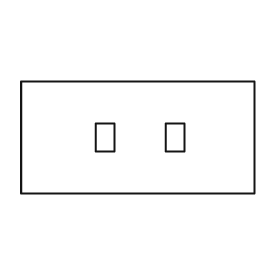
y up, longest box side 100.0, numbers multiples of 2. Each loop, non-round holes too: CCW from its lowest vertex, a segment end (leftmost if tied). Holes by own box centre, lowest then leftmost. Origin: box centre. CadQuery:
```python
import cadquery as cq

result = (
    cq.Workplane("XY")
    .moveTo(-50.0, -24.0)
    .lineTo(50.0, -24.0)
    .lineTo(50.0, 24.0)
    .lineTo(-50.0, 24.0)
    .close()
    .moveTo(-18.0, -6.0)
    .lineTo(-10.0, -6.0)
    .lineTo(-10.0, 6.0)
    .lineTo(-18.0, 6.0)
    .close()
    .moveTo(12.0, -6.0)
    .lineTo(20.0, -6.0)
    .lineTo(20.0, 6.0)
    .lineTo(12.0, 6.0)
    .close()
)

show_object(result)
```